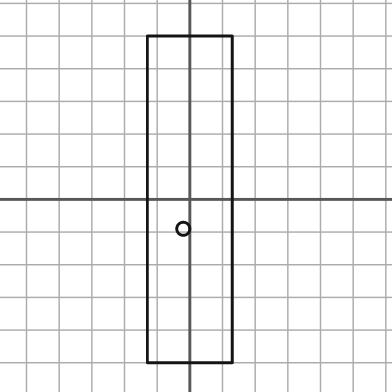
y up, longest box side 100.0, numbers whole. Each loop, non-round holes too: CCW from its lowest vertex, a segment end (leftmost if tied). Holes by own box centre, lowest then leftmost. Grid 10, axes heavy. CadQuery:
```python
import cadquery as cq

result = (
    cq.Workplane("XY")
    .moveTo(-13.0, -50.0)
    .lineTo(13.0, -50.0)
    .lineTo(13.0, 50.0)
    .lineTo(-13.0, 50.0)
    .close()
    .moveTo(-2.0, -9.0)
    .circle(2.0)
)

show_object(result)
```